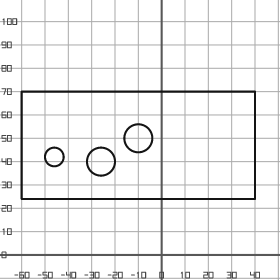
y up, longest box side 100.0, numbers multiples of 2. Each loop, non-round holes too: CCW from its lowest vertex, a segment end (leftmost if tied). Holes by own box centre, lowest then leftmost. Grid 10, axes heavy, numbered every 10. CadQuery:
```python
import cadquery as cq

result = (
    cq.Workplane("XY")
    .moveTo(-60.0, 24.0)
    .lineTo(40.0, 24.0)
    .lineTo(40.0, 70.0)
    .lineTo(-60.0, 70.0)
    .close()
    .moveTo(-26.0, 40.0)
    .circle(6.0)
    .moveTo(-46.0, 42.0)
    .circle(4.0)
    .moveTo(-10.0, 50.0)
    .circle(6.0)
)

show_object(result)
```